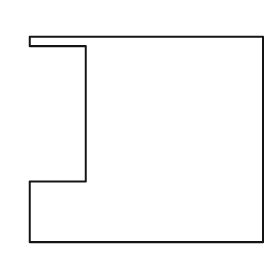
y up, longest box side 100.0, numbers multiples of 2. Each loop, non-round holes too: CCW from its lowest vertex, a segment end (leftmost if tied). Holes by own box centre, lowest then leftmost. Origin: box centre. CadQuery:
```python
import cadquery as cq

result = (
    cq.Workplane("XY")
    .moveTo(-50.0, -44.0)
    .lineTo(50.0, -44.0)
    .lineTo(50.0, 44.0)
    .lineTo(-50.0, 44.0)
    .lineTo(-50.0, 40.0)
    .lineTo(-26.0, 40.0)
    .lineTo(-26.0, -18.0)
    .lineTo(-50.0, -18.0)
    .close()
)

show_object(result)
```